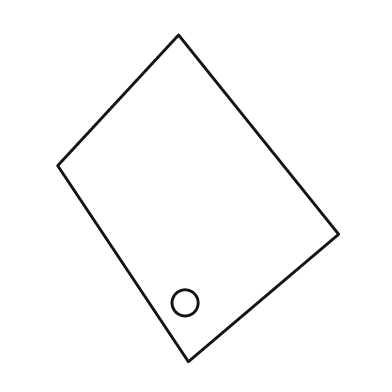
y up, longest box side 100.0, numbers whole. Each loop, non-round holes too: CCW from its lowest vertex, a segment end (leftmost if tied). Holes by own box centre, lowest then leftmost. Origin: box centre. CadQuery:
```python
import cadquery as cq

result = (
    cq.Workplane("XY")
    .moveTo(-3.0, -50.0)
    .lineTo(43.0, -11.0)
    .lineTo(-6.0, 50.0)
    .lineTo(-43.0, 10.0)
    .close()
    .moveTo(-4.0, -32.0)
    .circle(4.0)
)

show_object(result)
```